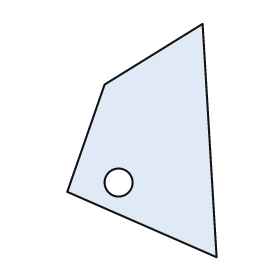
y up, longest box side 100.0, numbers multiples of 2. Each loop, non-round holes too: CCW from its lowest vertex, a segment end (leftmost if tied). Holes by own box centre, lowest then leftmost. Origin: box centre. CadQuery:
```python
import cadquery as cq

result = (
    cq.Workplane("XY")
    .moveTo(32.0, -50.0)
    .lineTo(26.0, 50.0)
    .lineTo(-16.0, 24.0)
    .lineTo(-32.0, -22.0)
    .close()
    .moveTo(-10.0, -18.0)
    .circle(6.0)
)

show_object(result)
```